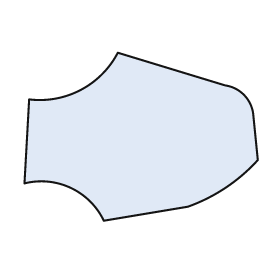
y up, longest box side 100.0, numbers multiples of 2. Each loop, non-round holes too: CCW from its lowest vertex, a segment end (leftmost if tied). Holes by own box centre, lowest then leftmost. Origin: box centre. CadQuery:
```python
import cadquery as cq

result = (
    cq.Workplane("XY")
    .moveTo(-16.0, -36.0)
    .lineTo(20.0, -30.0)
    .threePointArc((36.0, -22.0), (50.0, -10.0))
    .lineTo(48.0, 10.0)
    .threePointArc((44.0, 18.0), (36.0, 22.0))
    .lineTo(-10.0, 36.0)
    .threePointArc((-26.0, 20.0), (-48.0, 16.0))
    .lineTo(-50.0, -20.0)
    .threePointArc((-30.0, -22.0), (-16.0, -36.0))
    .close()
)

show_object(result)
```